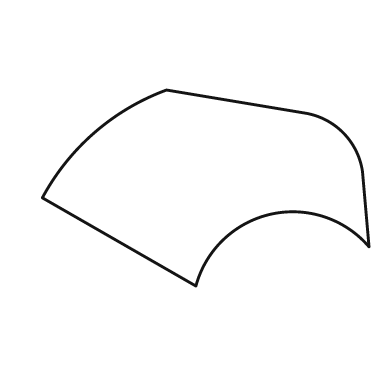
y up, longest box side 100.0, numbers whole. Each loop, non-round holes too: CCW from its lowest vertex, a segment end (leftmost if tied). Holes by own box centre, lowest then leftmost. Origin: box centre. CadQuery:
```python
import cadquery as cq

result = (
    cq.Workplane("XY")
    .moveTo(-3.0, -30.0)
    .threePointArc((20.0, -8.0), (50.0, -18.0))
    .lineTo(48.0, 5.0)
    .threePointArc((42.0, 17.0), (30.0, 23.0))
    .lineTo(-12.0, 30.0)
    .threePointArc((-34.0, 17.0), (-50.0, -3.0))
    .close()
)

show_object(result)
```